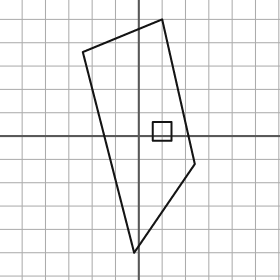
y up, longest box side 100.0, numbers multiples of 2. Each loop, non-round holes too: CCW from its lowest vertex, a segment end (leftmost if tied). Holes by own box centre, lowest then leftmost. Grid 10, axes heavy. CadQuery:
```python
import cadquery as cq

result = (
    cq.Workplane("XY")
    .moveTo(-2.0, -50.0)
    .lineTo(24.0, -12.0)
    .lineTo(10.0, 50.0)
    .lineTo(-24.0, 36.0)
    .close()
    .moveTo(6.0, -2.0)
    .lineTo(14.0, -2.0)
    .lineTo(14.0, 6.0)
    .lineTo(6.0, 6.0)
    .close()
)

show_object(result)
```